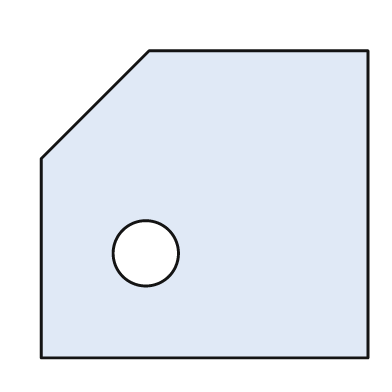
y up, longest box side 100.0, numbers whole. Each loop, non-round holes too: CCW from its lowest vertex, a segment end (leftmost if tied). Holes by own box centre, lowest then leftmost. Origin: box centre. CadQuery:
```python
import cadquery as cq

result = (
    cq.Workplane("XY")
    .moveTo(-50.0, -47.0)
    .lineTo(50.0, -47.0)
    .lineTo(50.0, 47.0)
    .lineTo(-17.0, 47.0)
    .lineTo(-50.0, 14.0)
    .close()
    .moveTo(-18.0, -15.0)
    .circle(10.0)
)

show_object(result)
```